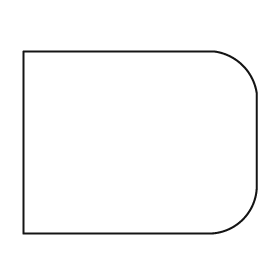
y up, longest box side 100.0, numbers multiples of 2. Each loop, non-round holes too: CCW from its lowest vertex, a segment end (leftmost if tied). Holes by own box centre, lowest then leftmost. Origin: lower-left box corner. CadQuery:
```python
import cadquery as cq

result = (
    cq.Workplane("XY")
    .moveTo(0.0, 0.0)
    .lineTo(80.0, 0.0)
    .threePointArc((94.0, 6.0), (100.0, 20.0))
    .lineTo(100.0, 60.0)
    .threePointArc((94.0, 72.0), (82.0, 78.0))
    .lineTo(0.0, 78.0)
    .close()
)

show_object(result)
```